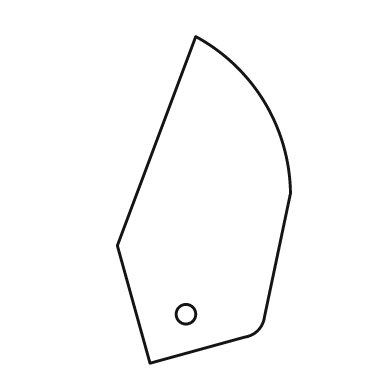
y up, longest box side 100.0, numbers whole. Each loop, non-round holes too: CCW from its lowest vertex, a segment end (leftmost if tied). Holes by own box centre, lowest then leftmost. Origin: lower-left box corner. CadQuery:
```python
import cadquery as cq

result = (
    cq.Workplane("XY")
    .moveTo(10.0, 0.0)
    .lineTo(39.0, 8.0)
    .threePointArc((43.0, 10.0), (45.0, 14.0))
    .lineTo(53.0, 52.0)
    .threePointArc((45.0, 80.0), (24.0, 100.0))
    .lineTo(0.0, 36.0)
    .close()
    .moveTo(21.0, 15.0)
    .circle(3.0)
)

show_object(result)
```